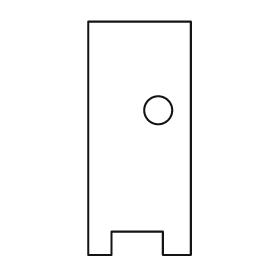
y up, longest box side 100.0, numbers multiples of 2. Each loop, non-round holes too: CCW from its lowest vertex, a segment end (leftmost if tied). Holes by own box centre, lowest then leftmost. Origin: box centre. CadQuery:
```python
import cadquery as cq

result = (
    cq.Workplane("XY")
    .moveTo(-22.0, -50.0)
    .lineTo(-12.0, -50.0)
    .lineTo(-12.0, -40.0)
    .lineTo(10.0, -40.0)
    .lineTo(10.0, -50.0)
    .lineTo(22.0, -50.0)
    .lineTo(22.0, 50.0)
    .lineTo(-22.0, 50.0)
    .close()
    .moveTo(8.0, 12.0)
    .circle(6.0)
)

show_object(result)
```